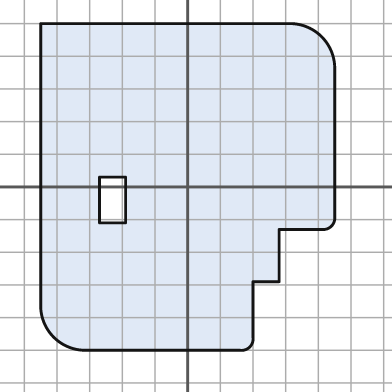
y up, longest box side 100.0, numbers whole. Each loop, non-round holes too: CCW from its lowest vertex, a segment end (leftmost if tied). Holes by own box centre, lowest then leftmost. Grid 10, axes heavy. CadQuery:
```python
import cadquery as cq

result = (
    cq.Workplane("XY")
    .moveTo(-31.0, -50.0)
    .lineTo(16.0, -50.0)
    .threePointArc((19.0, -49.0), (20.0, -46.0))
    .lineTo(20.0, -29.0)
    .lineTo(28.0, -29.0)
    .lineTo(28.0, -13.0)
    .lineTo(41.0, -13.0)
    .threePointArc((44.0, -12.0), (45.0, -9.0))
    .lineTo(45.0, 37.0)
    .threePointArc((41.0, 46.0), (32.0, 50.0))
    .lineTo(-45.0, 50.0)
    .lineTo(-45.0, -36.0)
    .threePointArc((-41.0, -46.0), (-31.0, -50.0))
    .close()
    .moveTo(-27.0, -11.0)
    .lineTo(-19.0, -11.0)
    .lineTo(-19.0, 3.0)
    .lineTo(-27.0, 3.0)
    .close()
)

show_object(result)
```